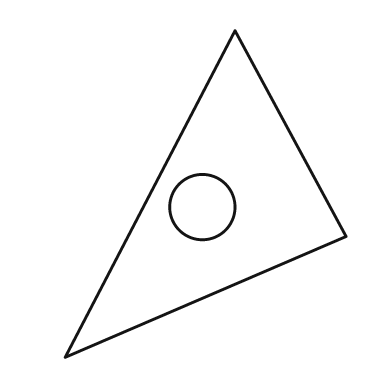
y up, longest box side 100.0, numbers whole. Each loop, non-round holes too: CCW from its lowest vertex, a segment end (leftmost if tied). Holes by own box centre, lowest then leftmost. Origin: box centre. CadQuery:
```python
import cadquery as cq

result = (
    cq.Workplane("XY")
    .moveTo(-43.0, -50.0)
    .lineTo(43.0, -13.0)
    .lineTo(9.0, 50.0)
    .close()
    .moveTo(-1.0, -4.0)
    .circle(10.0)
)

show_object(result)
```